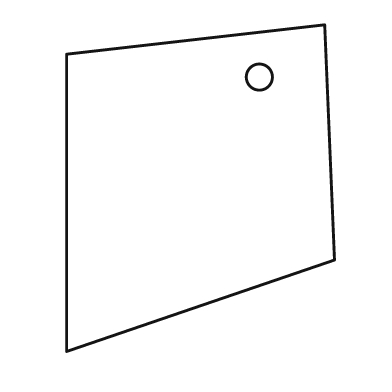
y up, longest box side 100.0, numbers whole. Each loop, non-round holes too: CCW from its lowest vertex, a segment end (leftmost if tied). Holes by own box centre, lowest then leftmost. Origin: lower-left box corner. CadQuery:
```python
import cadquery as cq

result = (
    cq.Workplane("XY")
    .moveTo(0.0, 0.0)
    .lineTo(82.0, 28.0)
    .lineTo(79.0, 100.0)
    .lineTo(0.0, 91.0)
    .close()
    .moveTo(59.0, 84.0)
    .circle(4.0)
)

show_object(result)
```